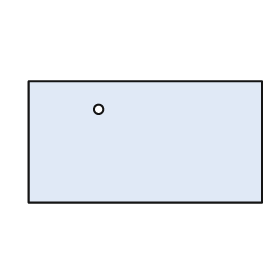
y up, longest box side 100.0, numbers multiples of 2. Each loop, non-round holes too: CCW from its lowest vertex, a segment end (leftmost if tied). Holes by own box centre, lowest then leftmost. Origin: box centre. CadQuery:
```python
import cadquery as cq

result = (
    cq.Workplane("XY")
    .moveTo(-50.0, -26.0)
    .lineTo(50.0, -26.0)
    .lineTo(50.0, 26.0)
    .lineTo(-50.0, 26.0)
    .close()
    .moveTo(-20.0, 14.0)
    .circle(2.0)
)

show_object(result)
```